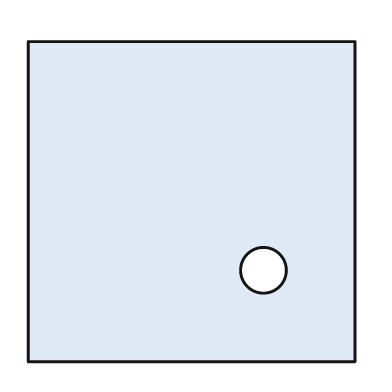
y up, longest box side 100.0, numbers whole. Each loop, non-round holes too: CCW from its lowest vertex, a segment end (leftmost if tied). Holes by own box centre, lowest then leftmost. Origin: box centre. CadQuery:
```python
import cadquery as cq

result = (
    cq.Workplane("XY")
    .moveTo(-50.0, -49.0)
    .lineTo(50.0, -49.0)
    .lineTo(50.0, 49.0)
    .lineTo(-50.0, 49.0)
    .close()
    .moveTo(22.0, -21.0)
    .circle(7.0)
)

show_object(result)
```